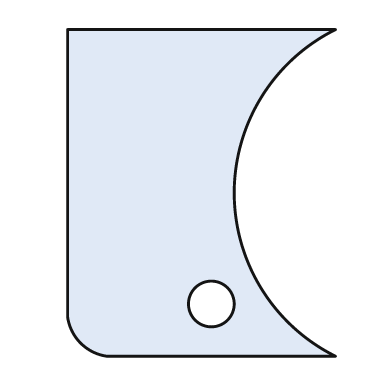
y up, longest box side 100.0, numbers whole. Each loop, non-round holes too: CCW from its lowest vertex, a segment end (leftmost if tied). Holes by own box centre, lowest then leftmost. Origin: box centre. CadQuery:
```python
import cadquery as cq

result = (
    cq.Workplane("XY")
    .moveTo(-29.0, -50.0)
    .lineTo(41.0, -50.0)
    .threePointArc((10.0, 0.0), (41.0, 50.0))
    .lineTo(-41.0, 50.0)
    .lineTo(-41.0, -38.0)
    .threePointArc((-37.0, -46.0), (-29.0, -50.0))
    .close()
    .moveTo(3.0, -34.0)
    .circle(7.0)
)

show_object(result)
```